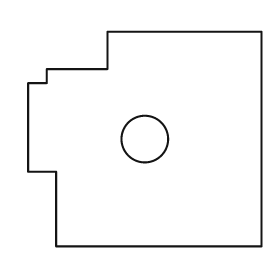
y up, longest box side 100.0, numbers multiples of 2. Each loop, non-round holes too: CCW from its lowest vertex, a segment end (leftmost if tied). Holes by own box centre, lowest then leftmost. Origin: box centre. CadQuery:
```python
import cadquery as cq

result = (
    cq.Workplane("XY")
    .moveTo(-38.0, -46.0)
    .lineTo(50.0, -46.0)
    .lineTo(50.0, 46.0)
    .lineTo(-16.0, 46.0)
    .lineTo(-16.0, 30.0)
    .lineTo(-42.0, 30.0)
    .lineTo(-42.0, 24.0)
    .lineTo(-50.0, 24.0)
    .lineTo(-50.0, -14.0)
    .lineTo(-38.0, -14.0)
    .close()
    .moveTo(0.0, 0.0)
    .circle(10.0)
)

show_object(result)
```